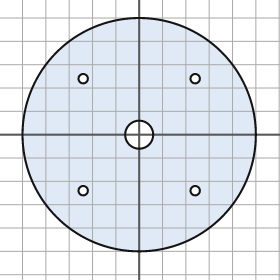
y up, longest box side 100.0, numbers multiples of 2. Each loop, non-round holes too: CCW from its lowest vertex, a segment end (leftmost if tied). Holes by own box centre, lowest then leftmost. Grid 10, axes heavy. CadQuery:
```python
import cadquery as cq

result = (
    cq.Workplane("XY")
    .moveTo(0.0, 0.0)
    .circle(50.0)
    .moveTo(-24.0, -24.0)
    .circle(2.0)
    .moveTo(24.0, -24.0)
    .circle(2.0)
    .moveTo(0.0, 0.0)
    .circle(6.0)
    .moveTo(-24.0, 24.0)
    .circle(2.0)
    .moveTo(24.0, 24.0)
    .circle(2.0)
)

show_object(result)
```